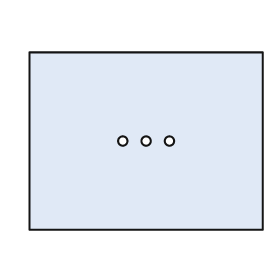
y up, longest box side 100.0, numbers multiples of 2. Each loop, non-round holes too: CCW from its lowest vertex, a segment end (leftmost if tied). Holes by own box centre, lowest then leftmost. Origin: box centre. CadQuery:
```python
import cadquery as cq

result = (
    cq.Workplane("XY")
    .moveTo(-50.0, -38.0)
    .lineTo(50.0, -38.0)
    .lineTo(50.0, 38.0)
    .lineTo(-50.0, 38.0)
    .close()
    .moveTo(-10.0, 0.0)
    .circle(2.0)
    .moveTo(0.0, 0.0)
    .circle(2.0)
    .moveTo(10.0, 0.0)
    .circle(2.0)
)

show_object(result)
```